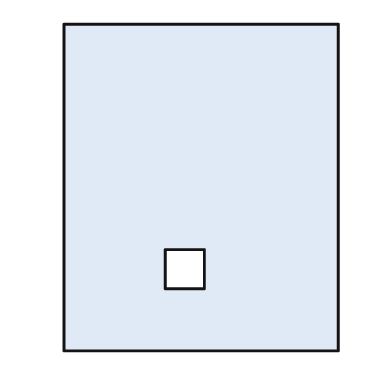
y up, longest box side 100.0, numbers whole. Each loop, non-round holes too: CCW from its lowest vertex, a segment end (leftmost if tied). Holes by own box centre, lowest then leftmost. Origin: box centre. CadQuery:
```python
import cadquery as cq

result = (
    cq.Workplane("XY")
    .moveTo(-42.0, -50.0)
    .lineTo(42.0, -50.0)
    .lineTo(42.0, 50.0)
    .lineTo(-42.0, 50.0)
    .close()
    .moveTo(-11.0, -31.0)
    .lineTo(1.0, -31.0)
    .lineTo(1.0, -19.0)
    .lineTo(-11.0, -19.0)
    .close()
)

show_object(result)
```